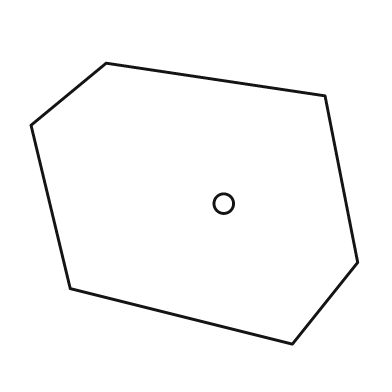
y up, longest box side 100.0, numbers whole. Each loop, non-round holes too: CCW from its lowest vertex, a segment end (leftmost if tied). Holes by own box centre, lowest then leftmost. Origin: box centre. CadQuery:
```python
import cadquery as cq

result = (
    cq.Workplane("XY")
    .moveTo(30.0, -43.0)
    .lineTo(50.0, -18.0)
    .lineTo(40.0, 33.0)
    .lineTo(-27.0, 43.0)
    .lineTo(-50.0, 24.0)
    .lineTo(-38.0, -26.0)
    .close()
    .moveTo(9.0, 0.0)
    .circle(3.0)
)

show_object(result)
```